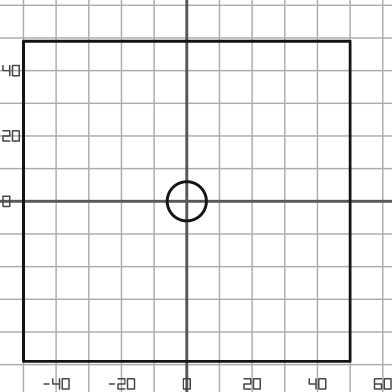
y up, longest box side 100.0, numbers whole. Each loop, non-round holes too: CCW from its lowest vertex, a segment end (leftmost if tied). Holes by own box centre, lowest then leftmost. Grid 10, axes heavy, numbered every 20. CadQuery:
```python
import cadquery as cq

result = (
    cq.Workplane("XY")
    .moveTo(-50.0, -49.0)
    .lineTo(50.0, -49.0)
    .lineTo(50.0, 49.0)
    .lineTo(-50.0, 49.0)
    .close()
    .moveTo(0.0, 0.0)
    .circle(6.0)
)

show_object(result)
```